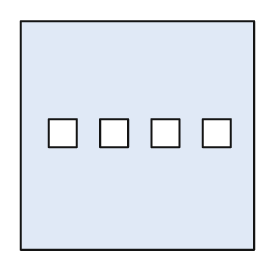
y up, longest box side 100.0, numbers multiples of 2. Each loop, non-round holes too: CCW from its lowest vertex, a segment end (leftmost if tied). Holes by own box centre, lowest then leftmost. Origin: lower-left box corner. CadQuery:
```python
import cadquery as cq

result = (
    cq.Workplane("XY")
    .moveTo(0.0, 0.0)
    .lineTo(100.0, 0.0)
    .lineTo(100.0, 98.0)
    .lineTo(0.0, 98.0)
    .close()
    .moveTo(12.0, 44.0)
    .lineTo(24.0, 44.0)
    .lineTo(24.0, 56.0)
    .lineTo(12.0, 56.0)
    .close()
    .moveTo(34.0, 44.0)
    .lineTo(46.0, 44.0)
    .lineTo(46.0, 56.0)
    .lineTo(34.0, 56.0)
    .close()
    .moveTo(56.0, 44.0)
    .lineTo(68.0, 44.0)
    .lineTo(68.0, 56.0)
    .lineTo(56.0, 56.0)
    .close()
    .moveTo(78.0, 44.0)
    .lineTo(90.0, 44.0)
    .lineTo(90.0, 56.0)
    .lineTo(78.0, 56.0)
    .close()
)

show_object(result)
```